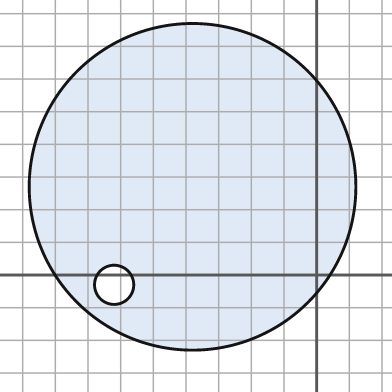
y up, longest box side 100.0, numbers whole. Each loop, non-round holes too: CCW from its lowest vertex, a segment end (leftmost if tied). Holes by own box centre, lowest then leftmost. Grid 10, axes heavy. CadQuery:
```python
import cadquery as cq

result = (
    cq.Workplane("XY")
    .moveTo(-38.0, 27.0)
    .circle(50.0)
    .moveTo(-62.0, -3.0)
    .circle(6.0)
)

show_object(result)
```